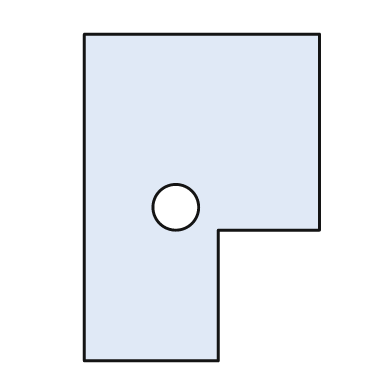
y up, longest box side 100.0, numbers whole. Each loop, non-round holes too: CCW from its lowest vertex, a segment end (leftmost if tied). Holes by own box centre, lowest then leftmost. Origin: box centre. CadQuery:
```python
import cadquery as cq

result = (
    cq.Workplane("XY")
    .moveTo(-36.0, -50.0)
    .lineTo(5.0, -50.0)
    .lineTo(5.0, -10.0)
    .lineTo(36.0, -10.0)
    .lineTo(36.0, 50.0)
    .lineTo(-36.0, 50.0)
    .close()
    .moveTo(-8.0, -3.0)
    .circle(7.0)
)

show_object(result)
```